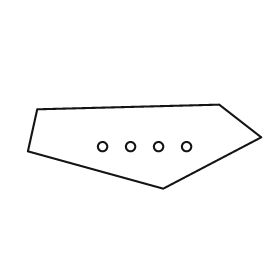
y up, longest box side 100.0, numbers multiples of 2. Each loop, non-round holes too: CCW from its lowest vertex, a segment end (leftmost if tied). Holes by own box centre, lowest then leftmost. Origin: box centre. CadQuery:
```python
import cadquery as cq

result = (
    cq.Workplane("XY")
    .moveTo(8.0, -18.0)
    .lineTo(50.0, 4.0)
    .lineTo(32.0, 18.0)
    .lineTo(-46.0, 16.0)
    .lineTo(-50.0, -2.0)
    .close()
    .moveTo(-18.0, 0.0)
    .circle(2.0)
    .moveTo(-6.0, 0.0)
    .circle(2.0)
    .moveTo(6.0, 0.0)
    .circle(2.0)
    .moveTo(18.0, 0.0)
    .circle(2.0)
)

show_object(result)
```